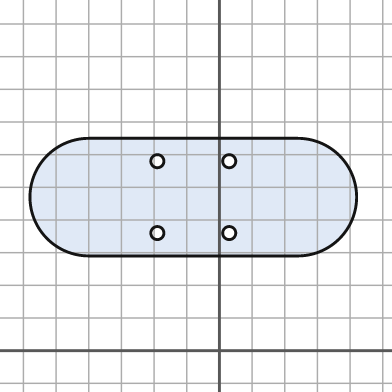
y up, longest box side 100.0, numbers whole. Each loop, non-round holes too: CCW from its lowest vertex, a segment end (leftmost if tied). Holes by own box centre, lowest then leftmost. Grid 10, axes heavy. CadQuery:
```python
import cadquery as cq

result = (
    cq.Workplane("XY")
    .moveTo(-40.0, 29.0)
    .lineTo(24.0, 29.0)
    .threePointArc((42.0, 47.0), (24.0, 65.0))
    .lineTo(-40.0, 65.0)
    .threePointArc((-58.0, 47.0), (-40.0, 29.0))
    .close()
    .moveTo(-19.0, 36.0)
    .circle(2.0)
    .moveTo(3.0, 36.0)
    .circle(2.0)
    .moveTo(-19.0, 58.0)
    .circle(2.0)
    .moveTo(3.0, 58.0)
    .circle(2.0)
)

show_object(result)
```